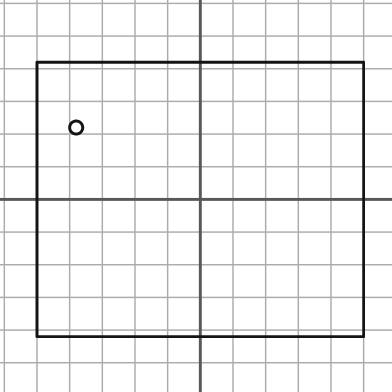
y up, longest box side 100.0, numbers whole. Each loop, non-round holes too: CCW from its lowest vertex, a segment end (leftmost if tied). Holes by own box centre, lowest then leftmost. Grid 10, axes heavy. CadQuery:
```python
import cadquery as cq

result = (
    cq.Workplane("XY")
    .moveTo(-50.0, -42.0)
    .lineTo(50.0, -42.0)
    .lineTo(50.0, 42.0)
    .lineTo(-50.0, 42.0)
    .close()
    .moveTo(-38.0, 22.0)
    .circle(2.0)
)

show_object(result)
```